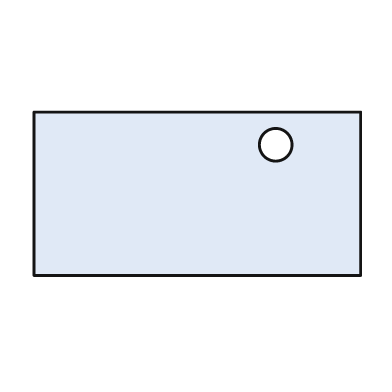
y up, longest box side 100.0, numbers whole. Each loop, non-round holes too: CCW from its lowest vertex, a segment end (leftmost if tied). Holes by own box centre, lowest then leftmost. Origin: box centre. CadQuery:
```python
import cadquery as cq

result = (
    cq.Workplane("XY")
    .moveTo(-50.0, -25.0)
    .lineTo(50.0, -25.0)
    .lineTo(50.0, 25.0)
    .lineTo(-50.0, 25.0)
    .close()
    .moveTo(24.0, 15.0)
    .circle(5.0)
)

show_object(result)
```